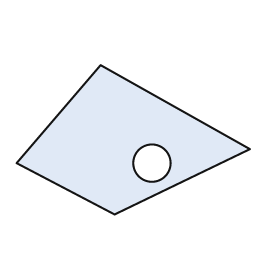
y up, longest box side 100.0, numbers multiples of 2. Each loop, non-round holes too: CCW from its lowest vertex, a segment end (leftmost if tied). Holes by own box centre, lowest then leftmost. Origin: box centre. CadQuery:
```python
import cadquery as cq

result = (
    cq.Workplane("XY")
    .moveTo(-8.0, -32.0)
    .lineTo(50.0, -4.0)
    .lineTo(-14.0, 32.0)
    .lineTo(-50.0, -10.0)
    .close()
    .moveTo(8.0, -10.0)
    .circle(8.0)
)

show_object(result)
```